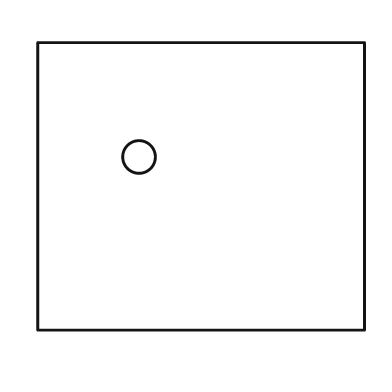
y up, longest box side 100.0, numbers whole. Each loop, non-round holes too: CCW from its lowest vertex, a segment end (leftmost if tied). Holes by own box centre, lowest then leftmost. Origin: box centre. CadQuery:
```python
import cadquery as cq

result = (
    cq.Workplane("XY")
    .moveTo(-50.0, -44.0)
    .lineTo(50.0, -44.0)
    .lineTo(50.0, 44.0)
    .lineTo(-50.0, 44.0)
    .close()
    .moveTo(-19.0, 9.0)
    .circle(5.0)
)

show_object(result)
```